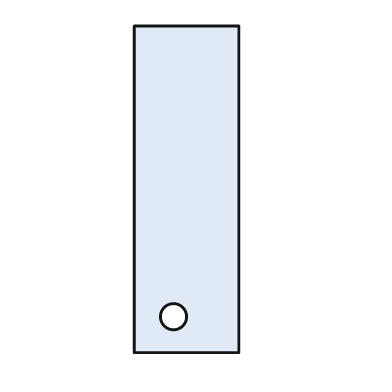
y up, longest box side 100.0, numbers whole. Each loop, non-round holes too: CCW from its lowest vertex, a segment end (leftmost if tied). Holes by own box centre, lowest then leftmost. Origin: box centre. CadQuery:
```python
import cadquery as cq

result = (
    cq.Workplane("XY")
    .moveTo(-16.0, -50.0)
    .lineTo(16.0, -50.0)
    .lineTo(16.0, 50.0)
    .lineTo(-16.0, 50.0)
    .close()
    .moveTo(-4.0, -39.0)
    .circle(4.0)
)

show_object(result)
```